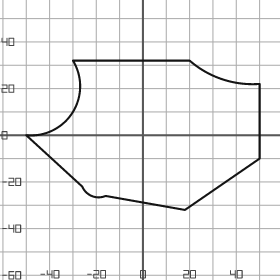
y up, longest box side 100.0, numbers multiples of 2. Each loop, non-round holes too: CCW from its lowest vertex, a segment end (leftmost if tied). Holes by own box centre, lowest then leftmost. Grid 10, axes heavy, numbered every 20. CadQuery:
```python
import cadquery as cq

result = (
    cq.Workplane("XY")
    .moveTo(18.0, -32.0)
    .lineTo(50.0, -10.0)
    .lineTo(50.0, 22.0)
    .threePointArc((34.0, 24.0), (20.0, 32.0))
    .lineTo(-30.0, 32.0)
    .threePointArc((-30.0, 10.0), (-50.0, 0.0))
    .lineTo(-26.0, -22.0)
    .threePointArc((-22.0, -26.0), (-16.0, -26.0))
    .close()
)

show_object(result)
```